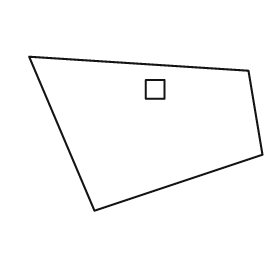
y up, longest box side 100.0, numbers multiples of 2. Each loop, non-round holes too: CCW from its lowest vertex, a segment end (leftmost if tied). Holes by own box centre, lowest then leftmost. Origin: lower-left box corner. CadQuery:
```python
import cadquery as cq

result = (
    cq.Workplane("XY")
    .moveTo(28.0, 0.0)
    .lineTo(100.0, 24.0)
    .lineTo(94.0, 60.0)
    .lineTo(0.0, 66.0)
    .close()
    .moveTo(50.0, 48.0)
    .lineTo(58.0, 48.0)
    .lineTo(58.0, 56.0)
    .lineTo(50.0, 56.0)
    .close()
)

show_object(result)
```